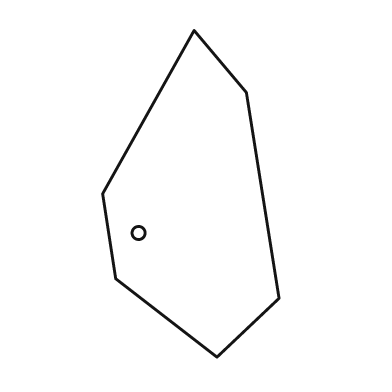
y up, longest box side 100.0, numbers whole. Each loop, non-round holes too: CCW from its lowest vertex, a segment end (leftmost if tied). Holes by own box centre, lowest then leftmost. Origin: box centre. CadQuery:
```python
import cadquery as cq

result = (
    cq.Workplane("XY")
    .moveTo(8.0, -50.0)
    .lineTo(27.0, -32.0)
    .lineTo(17.0, 31.0)
    .lineTo(1.0, 50.0)
    .lineTo(-27.0, 0.0)
    .lineTo(-23.0, -26.0)
    .close()
    .moveTo(-16.0, -12.0)
    .circle(2.0)
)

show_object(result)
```